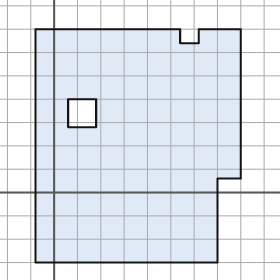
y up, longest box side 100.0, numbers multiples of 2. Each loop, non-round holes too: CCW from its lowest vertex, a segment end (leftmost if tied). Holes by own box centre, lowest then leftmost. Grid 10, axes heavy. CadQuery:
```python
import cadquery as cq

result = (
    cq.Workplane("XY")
    .moveTo(-8.0, -30.0)
    .lineTo(70.0, -30.0)
    .lineTo(70.0, 6.0)
    .lineTo(80.0, 6.0)
    .lineTo(80.0, 70.0)
    .lineTo(62.0, 70.0)
    .lineTo(62.0, 64.0)
    .lineTo(54.0, 64.0)
    .lineTo(54.0, 70.0)
    .lineTo(-8.0, 70.0)
    .close()
    .moveTo(6.0, 28.0)
    .lineTo(18.0, 28.0)
    .lineTo(18.0, 40.0)
    .lineTo(6.0, 40.0)
    .close()
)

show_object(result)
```